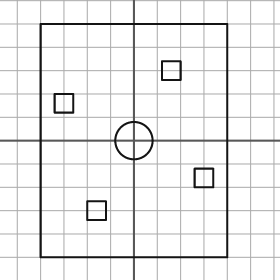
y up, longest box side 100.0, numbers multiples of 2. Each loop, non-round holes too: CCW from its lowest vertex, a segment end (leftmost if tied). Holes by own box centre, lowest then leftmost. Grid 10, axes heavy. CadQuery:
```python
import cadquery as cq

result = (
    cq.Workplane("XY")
    .moveTo(-40.0, -50.0)
    .lineTo(40.0, -50.0)
    .lineTo(40.0, 50.0)
    .lineTo(-40.0, 50.0)
    .close()
    .moveTo(-20.0, -34.0)
    .lineTo(-12.0, -34.0)
    .lineTo(-12.0, -26.0)
    .lineTo(-20.0, -26.0)
    .close()
    .moveTo(26.0, -20.0)
    .lineTo(34.0, -20.0)
    .lineTo(34.0, -12.0)
    .lineTo(26.0, -12.0)
    .close()
    .moveTo(0.0, 0.0)
    .circle(8.0)
    .moveTo(-34.0, 12.0)
    .lineTo(-26.0, 12.0)
    .lineTo(-26.0, 20.0)
    .lineTo(-34.0, 20.0)
    .close()
    .moveTo(12.0, 26.0)
    .lineTo(20.0, 26.0)
    .lineTo(20.0, 34.0)
    .lineTo(12.0, 34.0)
    .close()
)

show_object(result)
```